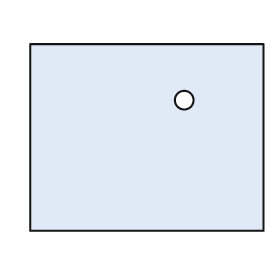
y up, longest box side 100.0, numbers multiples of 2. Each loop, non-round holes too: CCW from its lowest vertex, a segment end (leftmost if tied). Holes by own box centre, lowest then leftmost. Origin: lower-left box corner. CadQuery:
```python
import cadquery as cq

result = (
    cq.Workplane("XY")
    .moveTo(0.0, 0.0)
    .lineTo(100.0, 0.0)
    .lineTo(100.0, 80.0)
    .lineTo(0.0, 80.0)
    .close()
    .moveTo(66.0, 56.0)
    .circle(4.0)
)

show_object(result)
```